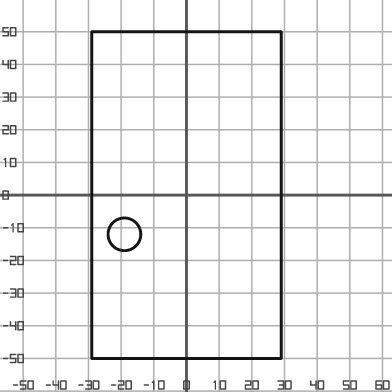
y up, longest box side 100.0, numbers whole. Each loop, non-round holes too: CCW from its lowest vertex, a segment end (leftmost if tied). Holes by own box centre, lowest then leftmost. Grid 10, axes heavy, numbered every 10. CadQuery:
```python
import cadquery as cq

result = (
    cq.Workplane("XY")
    .moveTo(-29.0, -50.0)
    .lineTo(29.0, -50.0)
    .lineTo(29.0, 50.0)
    .lineTo(-29.0, 50.0)
    .close()
    .moveTo(-19.0, -12.0)
    .circle(5.0)
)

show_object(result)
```